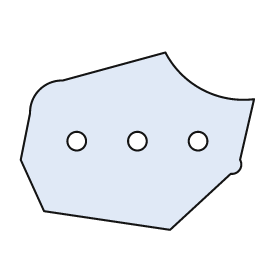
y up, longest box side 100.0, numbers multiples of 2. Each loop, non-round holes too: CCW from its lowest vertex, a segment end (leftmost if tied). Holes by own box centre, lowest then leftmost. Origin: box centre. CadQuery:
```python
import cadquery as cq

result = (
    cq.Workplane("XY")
    .moveTo(14.0, -38.0)
    .lineTo(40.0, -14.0)
    .threePointArc((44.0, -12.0), (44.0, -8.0))
    .lineTo(50.0, 18.0)
    .threePointArc((28.0, 22.0), (12.0, 38.0))
    .lineTo(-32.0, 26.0)
    .threePointArc((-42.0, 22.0), (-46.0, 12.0))
    .lineTo(-50.0, -8.0)
    .lineTo(-40.0, -30.0)
    .close()
    .moveTo(-26.0, 0.0)
    .circle(4.0)
    .moveTo(0.0, 0.0)
    .circle(4.0)
    .moveTo(26.0, 0.0)
    .circle(4.0)
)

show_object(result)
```